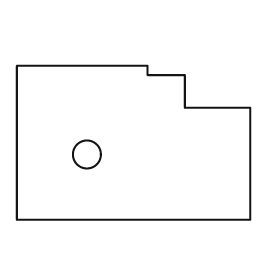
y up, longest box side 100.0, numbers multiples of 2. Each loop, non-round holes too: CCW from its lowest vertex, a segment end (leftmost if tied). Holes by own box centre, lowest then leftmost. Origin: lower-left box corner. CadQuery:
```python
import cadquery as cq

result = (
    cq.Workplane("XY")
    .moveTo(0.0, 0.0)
    .lineTo(100.0, 0.0)
    .lineTo(100.0, 48.0)
    .lineTo(72.0, 48.0)
    .lineTo(72.0, 62.0)
    .lineTo(56.0, 62.0)
    .lineTo(56.0, 66.0)
    .lineTo(0.0, 66.0)
    .close()
    .moveTo(30.0, 28.0)
    .circle(6.0)
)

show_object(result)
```